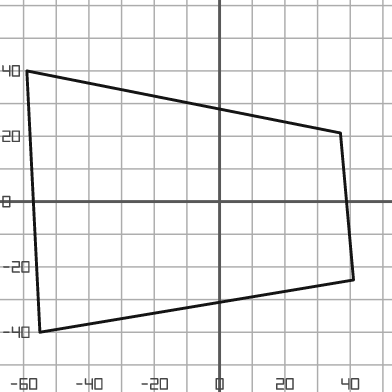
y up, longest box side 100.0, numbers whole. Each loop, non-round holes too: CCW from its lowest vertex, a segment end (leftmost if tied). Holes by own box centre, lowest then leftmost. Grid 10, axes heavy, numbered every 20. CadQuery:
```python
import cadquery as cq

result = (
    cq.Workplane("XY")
    .moveTo(-55.0, -40.0)
    .lineTo(41.0, -24.0)
    .lineTo(37.0, 21.0)
    .lineTo(-59.0, 40.0)
    .close()
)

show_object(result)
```